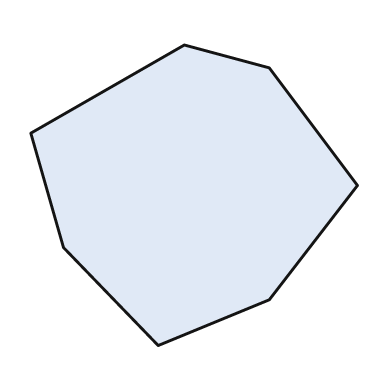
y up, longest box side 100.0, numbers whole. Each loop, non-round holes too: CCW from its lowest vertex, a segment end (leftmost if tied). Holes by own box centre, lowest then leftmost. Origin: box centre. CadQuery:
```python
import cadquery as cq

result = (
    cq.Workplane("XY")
    .moveTo(-11.0, -46.0)
    .lineTo(23.0, -32.0)
    .lineTo(50.0, 3.0)
    .lineTo(23.0, 39.0)
    .lineTo(-3.0, 46.0)
    .lineTo(-50.0, 19.0)
    .lineTo(-40.0, -16.0)
    .close()
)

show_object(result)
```